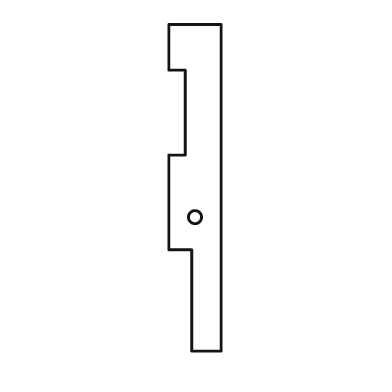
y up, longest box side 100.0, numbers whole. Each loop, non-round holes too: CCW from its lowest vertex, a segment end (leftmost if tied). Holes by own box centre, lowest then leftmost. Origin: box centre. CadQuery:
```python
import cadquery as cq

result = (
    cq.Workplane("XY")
    .moveTo(-1.0, -50.0)
    .lineTo(8.0, -50.0)
    .lineTo(8.0, 50.0)
    .lineTo(-8.0, 50.0)
    .lineTo(-8.0, 36.0)
    .lineTo(-3.0, 36.0)
    .lineTo(-3.0, 10.0)
    .lineTo(-8.0, 10.0)
    .lineTo(-8.0, -19.0)
    .lineTo(-1.0, -19.0)
    .close()
    .moveTo(0.0, -9.0)
    .circle(2.0)
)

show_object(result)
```